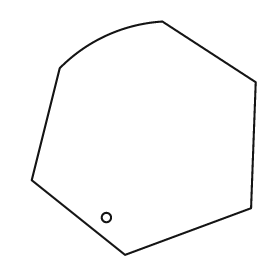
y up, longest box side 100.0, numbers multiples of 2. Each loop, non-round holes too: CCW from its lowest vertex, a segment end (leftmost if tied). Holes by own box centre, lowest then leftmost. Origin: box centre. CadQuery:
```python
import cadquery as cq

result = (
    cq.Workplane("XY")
    .moveTo(-8.0, -50.0)
    .lineTo(46.0, -30.0)
    .lineTo(48.0, 24.0)
    .lineTo(8.0, 50.0)
    .threePointArc((-16.0, 44.0), (-36.0, 30.0))
    .lineTo(-48.0, -18.0)
    .close()
    .moveTo(-16.0, -34.0)
    .circle(2.0)
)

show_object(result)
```